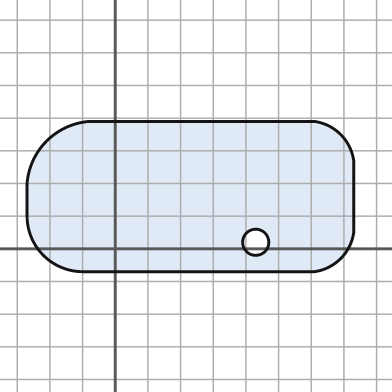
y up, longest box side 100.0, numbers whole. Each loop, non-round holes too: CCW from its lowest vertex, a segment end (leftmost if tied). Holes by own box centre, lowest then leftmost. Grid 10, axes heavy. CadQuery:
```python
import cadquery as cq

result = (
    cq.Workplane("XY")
    .moveTo(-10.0, -7.0)
    .lineTo(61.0, -7.0)
    .threePointArc((69.0, -3.0), (73.0, 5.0))
    .lineTo(73.0, 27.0)
    .threePointArc((69.0, 35.0), (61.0, 39.0))
    .lineTo(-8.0, 39.0)
    .threePointArc((-21.0, 33.0), (-27.0, 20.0))
    .lineTo(-27.0, 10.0)
    .threePointArc((-22.0, -2.0), (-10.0, -7.0))
    .close()
    .moveTo(43.0, 2.0)
    .circle(4.0)
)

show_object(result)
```